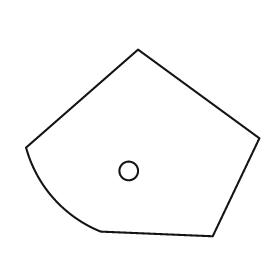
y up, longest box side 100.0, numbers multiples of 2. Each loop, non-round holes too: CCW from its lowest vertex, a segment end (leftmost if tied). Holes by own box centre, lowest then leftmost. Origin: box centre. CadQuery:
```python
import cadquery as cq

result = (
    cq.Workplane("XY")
    .moveTo(30.0, -40.0)
    .lineTo(50.0, 2.0)
    .lineTo(-2.0, 40.0)
    .lineTo(-50.0, -2.0)
    .threePointArc((-38.0, -24.0), (-18.0, -38.0))
    .close()
    .moveTo(-6.0, -12.0)
    .circle(4.0)
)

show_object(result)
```